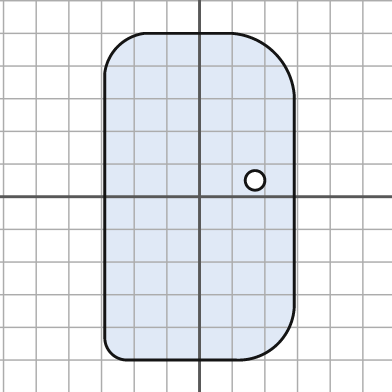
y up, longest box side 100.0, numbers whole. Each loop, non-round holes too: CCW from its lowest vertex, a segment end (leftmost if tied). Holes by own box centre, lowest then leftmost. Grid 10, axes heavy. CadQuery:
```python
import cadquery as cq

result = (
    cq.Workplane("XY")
    .moveTo(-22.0, -50.0)
    .lineTo(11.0, -50.0)
    .threePointArc((24.0, -45.0), (29.0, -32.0))
    .lineTo(29.0, 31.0)
    .threePointArc((23.0, 44.0), (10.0, 50.0))
    .lineTo(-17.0, 50.0)
    .threePointArc((-25.0, 46.0), (-29.0, 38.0))
    .lineTo(-29.0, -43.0)
    .threePointArc((-27.0, -48.0), (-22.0, -50.0))
    .close()
    .moveTo(17.0, 5.0)
    .circle(3.0)
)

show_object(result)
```